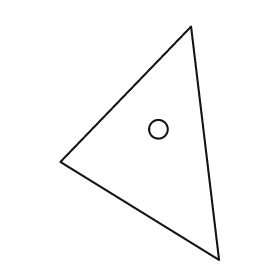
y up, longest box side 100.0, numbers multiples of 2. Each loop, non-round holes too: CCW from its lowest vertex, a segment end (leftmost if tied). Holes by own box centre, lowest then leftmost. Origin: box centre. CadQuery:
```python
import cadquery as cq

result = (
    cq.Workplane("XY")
    .moveTo(34.0, -50.0)
    .lineTo(22.0, 50.0)
    .lineTo(-34.0, -8.0)
    .close()
    .moveTo(8.0, 6.0)
    .circle(4.0)
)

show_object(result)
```